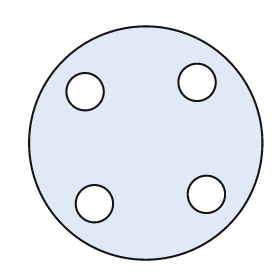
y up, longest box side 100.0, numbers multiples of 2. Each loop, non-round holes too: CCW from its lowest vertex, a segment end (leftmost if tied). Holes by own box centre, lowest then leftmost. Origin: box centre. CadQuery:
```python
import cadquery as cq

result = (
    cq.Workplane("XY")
    .moveTo(0.0, 0.0)
    .circle(50.0)
    .moveTo(-22.0, -26.0)
    .circle(8.0)
    .moveTo(26.0, -22.0)
    .circle(8.0)
    .moveTo(-26.0, 22.0)
    .circle(8.0)
    .moveTo(22.0, 26.0)
    .circle(8.0)
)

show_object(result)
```